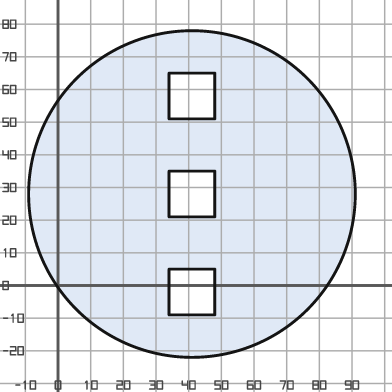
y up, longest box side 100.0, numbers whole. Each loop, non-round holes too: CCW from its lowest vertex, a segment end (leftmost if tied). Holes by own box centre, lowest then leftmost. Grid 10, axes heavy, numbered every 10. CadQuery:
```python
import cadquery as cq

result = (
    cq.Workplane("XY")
    .moveTo(41.0, 28.0)
    .circle(50.0)
    .moveTo(34.0, -9.0)
    .lineTo(48.0, -9.0)
    .lineTo(48.0, 5.0)
    .lineTo(34.0, 5.0)
    .close()
    .moveTo(34.0, 21.0)
    .lineTo(48.0, 21.0)
    .lineTo(48.0, 35.0)
    .lineTo(34.0, 35.0)
    .close()
    .moveTo(34.0, 51.0)
    .lineTo(48.0, 51.0)
    .lineTo(48.0, 65.0)
    .lineTo(34.0, 65.0)
    .close()
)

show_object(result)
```